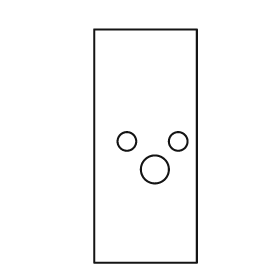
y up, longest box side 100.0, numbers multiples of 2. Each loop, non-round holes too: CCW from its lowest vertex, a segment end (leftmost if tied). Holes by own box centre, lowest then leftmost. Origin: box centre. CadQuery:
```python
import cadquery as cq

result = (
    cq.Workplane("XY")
    .moveTo(-22.0, -50.0)
    .lineTo(22.0, -50.0)
    .lineTo(22.0, 50.0)
    .lineTo(-22.0, 50.0)
    .close()
    .moveTo(4.0, -10.0)
    .circle(6.0)
    .moveTo(-8.0, 2.0)
    .circle(4.0)
    .moveTo(14.0, 2.0)
    .circle(4.0)
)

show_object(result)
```